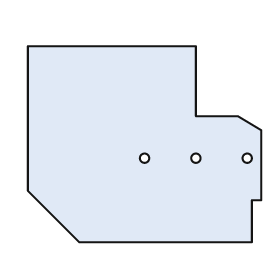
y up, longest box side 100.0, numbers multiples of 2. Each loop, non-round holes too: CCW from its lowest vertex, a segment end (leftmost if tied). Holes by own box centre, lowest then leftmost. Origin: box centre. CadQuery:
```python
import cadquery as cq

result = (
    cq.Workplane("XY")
    .moveTo(-28.0, -42.0)
    .lineTo(46.0, -42.0)
    .lineTo(46.0, -24.0)
    .lineTo(50.0, -24.0)
    .lineTo(50.0, 6.0)
    .lineTo(40.0, 12.0)
    .lineTo(22.0, 12.0)
    .lineTo(22.0, 42.0)
    .lineTo(-50.0, 42.0)
    .lineTo(-50.0, -20.0)
    .close()
    .moveTo(0.0, -6.0)
    .circle(2.0)
    .moveTo(22.0, -6.0)
    .circle(2.0)
    .moveTo(44.0, -6.0)
    .circle(2.0)
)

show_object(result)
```